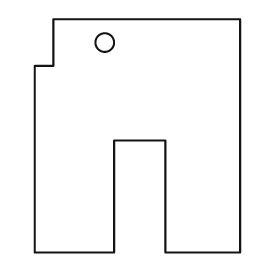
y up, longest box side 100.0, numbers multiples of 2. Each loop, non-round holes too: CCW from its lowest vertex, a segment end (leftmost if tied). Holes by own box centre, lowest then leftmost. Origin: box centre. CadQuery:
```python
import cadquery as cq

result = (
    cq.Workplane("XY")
    .moveTo(-44.0, -50.0)
    .lineTo(-10.0, -50.0)
    .lineTo(-10.0, -2.0)
    .lineTo(12.0, -2.0)
    .lineTo(12.0, -50.0)
    .lineTo(44.0, -50.0)
    .lineTo(44.0, 50.0)
    .lineTo(-36.0, 50.0)
    .lineTo(-36.0, 30.0)
    .lineTo(-44.0, 30.0)
    .close()
    .moveTo(-14.0, 40.0)
    .circle(4.0)
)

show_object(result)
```